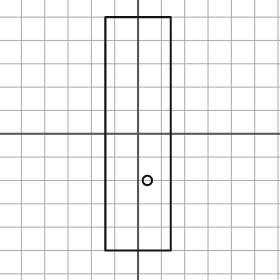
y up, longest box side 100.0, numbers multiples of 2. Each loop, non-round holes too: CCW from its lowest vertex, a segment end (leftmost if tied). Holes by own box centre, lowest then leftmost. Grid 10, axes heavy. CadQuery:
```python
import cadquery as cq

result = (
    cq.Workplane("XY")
    .moveTo(-14.0, -50.0)
    .lineTo(14.0, -50.0)
    .lineTo(14.0, 50.0)
    .lineTo(-14.0, 50.0)
    .close()
    .moveTo(4.0, -20.0)
    .circle(2.0)
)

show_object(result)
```